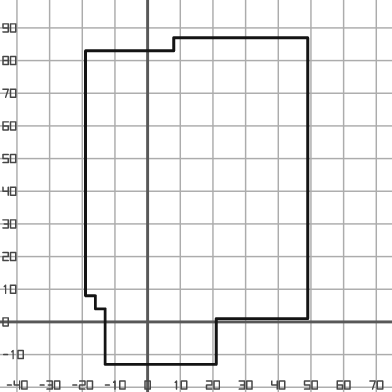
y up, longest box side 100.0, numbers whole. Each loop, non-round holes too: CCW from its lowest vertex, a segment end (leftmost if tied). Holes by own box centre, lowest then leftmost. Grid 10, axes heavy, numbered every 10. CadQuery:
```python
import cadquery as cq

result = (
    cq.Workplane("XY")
    .moveTo(-13.0, -13.0)
    .lineTo(21.0, -13.0)
    .lineTo(21.0, 1.0)
    .lineTo(49.0, 1.0)
    .lineTo(49.0, 87.0)
    .lineTo(8.0, 87.0)
    .lineTo(8.0, 83.0)
    .lineTo(-19.0, 83.0)
    .lineTo(-19.0, 8.0)
    .lineTo(-16.0, 8.0)
    .lineTo(-16.0, 4.0)
    .lineTo(-13.0, 4.0)
    .close()
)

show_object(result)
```